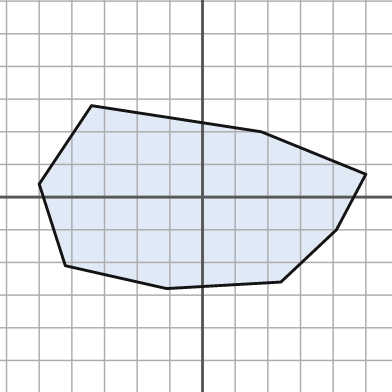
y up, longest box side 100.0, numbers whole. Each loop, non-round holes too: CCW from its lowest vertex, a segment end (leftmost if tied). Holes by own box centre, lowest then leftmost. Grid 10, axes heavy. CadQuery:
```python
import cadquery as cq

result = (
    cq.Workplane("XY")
    .moveTo(-11.0, -28.0)
    .lineTo(24.0, -26.0)
    .lineTo(41.0, -10.0)
    .lineTo(50.0, 7.0)
    .lineTo(18.0, 20.0)
    .lineTo(-34.0, 28.0)
    .lineTo(-50.0, 4.0)
    .lineTo(-42.0, -21.0)
    .close()
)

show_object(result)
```